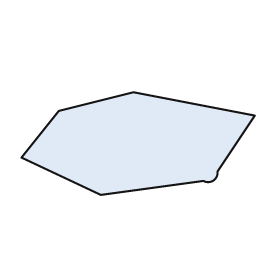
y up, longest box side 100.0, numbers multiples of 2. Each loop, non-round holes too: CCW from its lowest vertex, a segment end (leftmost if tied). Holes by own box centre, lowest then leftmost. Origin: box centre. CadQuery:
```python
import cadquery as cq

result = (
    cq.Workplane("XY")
    .moveTo(-16.0, -22.0)
    .lineTo(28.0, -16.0)
    .threePointArc((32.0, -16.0), (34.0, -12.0))
    .lineTo(50.0, 12.0)
    .lineTo(-2.0, 22.0)
    .lineTo(-34.0, 14.0)
    .lineTo(-50.0, -6.0)
    .close()
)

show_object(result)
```